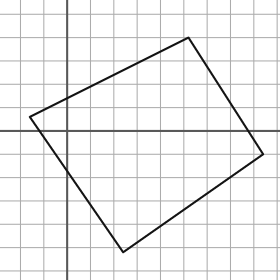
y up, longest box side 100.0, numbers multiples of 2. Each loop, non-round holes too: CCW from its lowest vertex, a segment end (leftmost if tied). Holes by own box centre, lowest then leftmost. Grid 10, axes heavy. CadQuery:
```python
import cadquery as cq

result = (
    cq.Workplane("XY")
    .moveTo(24.0, -52.0)
    .lineTo(84.0, -10.0)
    .lineTo(52.0, 40.0)
    .lineTo(-16.0, 6.0)
    .close()
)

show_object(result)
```